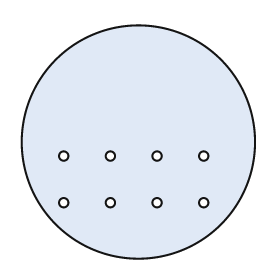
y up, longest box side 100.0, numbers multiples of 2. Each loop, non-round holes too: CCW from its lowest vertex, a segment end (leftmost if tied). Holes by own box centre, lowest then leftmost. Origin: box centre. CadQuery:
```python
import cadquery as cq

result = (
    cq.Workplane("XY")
    .moveTo(0.0, 0.0)
    .circle(50.0)
    .moveTo(-32.0, -26.0)
    .circle(2.0)
    .moveTo(-12.0, -26.0)
    .circle(2.0)
    .moveTo(8.0, -26.0)
    .circle(2.0)
    .moveTo(28.0, -26.0)
    .circle(2.0)
    .moveTo(-32.0, -6.0)
    .circle(2.0)
    .moveTo(-12.0, -6.0)
    .circle(2.0)
    .moveTo(8.0, -6.0)
    .circle(2.0)
    .moveTo(28.0, -6.0)
    .circle(2.0)
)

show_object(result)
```